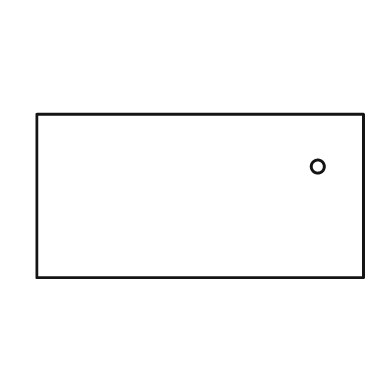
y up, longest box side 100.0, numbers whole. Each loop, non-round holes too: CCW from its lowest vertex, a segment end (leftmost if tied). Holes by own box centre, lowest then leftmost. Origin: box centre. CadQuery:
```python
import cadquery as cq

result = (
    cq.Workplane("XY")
    .moveTo(-50.0, -25.0)
    .lineTo(50.0, -25.0)
    .lineTo(50.0, 25.0)
    .lineTo(-50.0, 25.0)
    .close()
    .moveTo(36.0, 9.0)
    .circle(2.0)
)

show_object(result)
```